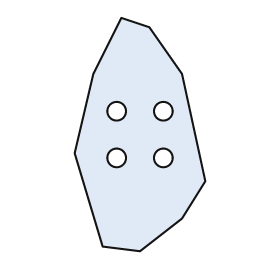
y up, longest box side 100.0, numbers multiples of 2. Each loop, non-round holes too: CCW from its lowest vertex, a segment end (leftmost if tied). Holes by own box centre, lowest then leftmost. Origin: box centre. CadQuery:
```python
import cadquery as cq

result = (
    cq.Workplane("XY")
    .moveTo(0.0, -50.0)
    .lineTo(18.0, -36.0)
    .lineTo(28.0, -20.0)
    .lineTo(18.0, 26.0)
    .lineTo(4.0, 46.0)
    .lineTo(-8.0, 50.0)
    .lineTo(-20.0, 26.0)
    .lineTo(-28.0, -8.0)
    .lineTo(-16.0, -48.0)
    .close()
    .moveTo(-10.0, -10.0)
    .circle(4.0)
    .moveTo(10.0, -10.0)
    .circle(4.0)
    .moveTo(-10.0, 10.0)
    .circle(4.0)
    .moveTo(10.0, 10.0)
    .circle(4.0)
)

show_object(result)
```